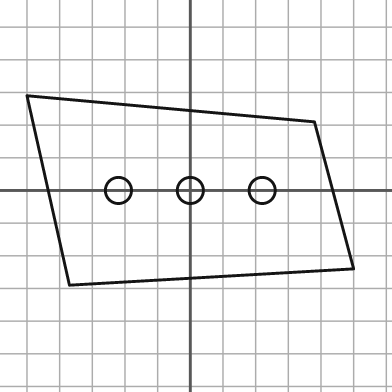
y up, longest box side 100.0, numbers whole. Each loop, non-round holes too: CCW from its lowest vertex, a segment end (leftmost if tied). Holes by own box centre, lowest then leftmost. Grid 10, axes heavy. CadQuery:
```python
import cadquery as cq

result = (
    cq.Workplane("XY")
    .moveTo(-37.0, -29.0)
    .lineTo(50.0, -24.0)
    .lineTo(38.0, 21.0)
    .lineTo(-50.0, 29.0)
    .close()
    .moveTo(-22.0, 0.0)
    .circle(4.0)
    .moveTo(0.0, 0.0)
    .circle(4.0)
    .moveTo(22.0, 0.0)
    .circle(4.0)
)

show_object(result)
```